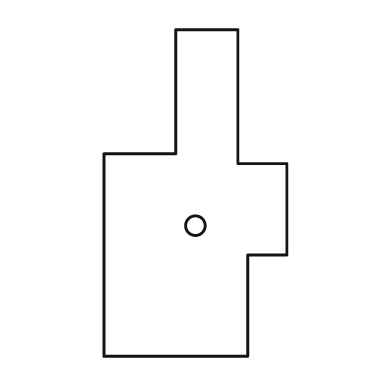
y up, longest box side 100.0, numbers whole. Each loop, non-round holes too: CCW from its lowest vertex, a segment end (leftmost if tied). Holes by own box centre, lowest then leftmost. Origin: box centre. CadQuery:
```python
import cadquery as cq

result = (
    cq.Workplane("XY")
    .moveTo(-28.0, -50.0)
    .lineTo(16.0, -50.0)
    .lineTo(16.0, -19.0)
    .lineTo(28.0, -19.0)
    .lineTo(28.0, 9.0)
    .lineTo(13.0, 9.0)
    .lineTo(13.0, 50.0)
    .lineTo(-6.0, 50.0)
    .lineTo(-6.0, 12.0)
    .lineTo(-28.0, 12.0)
    .close()
    .moveTo(0.0, -10.0)
    .circle(3.0)
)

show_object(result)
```